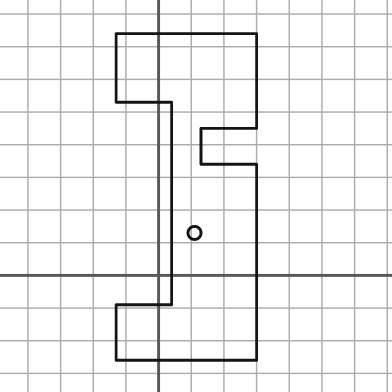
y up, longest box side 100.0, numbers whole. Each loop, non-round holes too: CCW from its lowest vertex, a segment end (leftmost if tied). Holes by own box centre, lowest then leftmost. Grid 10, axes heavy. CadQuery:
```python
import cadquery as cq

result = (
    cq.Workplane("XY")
    .moveTo(-13.0, -26.0)
    .lineTo(30.0, -26.0)
    .lineTo(30.0, 34.0)
    .lineTo(13.0, 34.0)
    .lineTo(13.0, 45.0)
    .lineTo(30.0, 45.0)
    .lineTo(30.0, 74.0)
    .lineTo(-13.0, 74.0)
    .lineTo(-13.0, 53.0)
    .lineTo(4.0, 53.0)
    .lineTo(4.0, -9.0)
    .lineTo(-13.0, -9.0)
    .close()
    .moveTo(11.0, 13.0)
    .circle(2.0)
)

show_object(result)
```